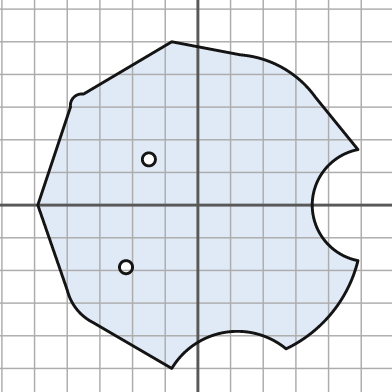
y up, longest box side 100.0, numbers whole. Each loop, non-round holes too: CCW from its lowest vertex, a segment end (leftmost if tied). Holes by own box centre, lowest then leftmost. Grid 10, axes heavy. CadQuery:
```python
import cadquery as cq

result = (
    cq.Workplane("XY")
    .moveTo(-8.0, -50.0)
    .threePointArc((8.0, -39.0), (27.0, -44.0))
    .threePointArc((41.0, -33.0), (49.0, -17.0))
    .threePointArc((35.0, 0.0), (49.0, 17.0))
    .lineTo(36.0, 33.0)
    .threePointArc((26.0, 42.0), (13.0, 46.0))
    .lineTo(-8.0, 50.0)
    .lineTo(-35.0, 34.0)
    .threePointArc((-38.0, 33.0), (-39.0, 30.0))
    .lineTo(-49.0, 0.0)
    .lineTo(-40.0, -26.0)
    .threePointArc((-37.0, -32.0), (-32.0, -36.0))
    .close()
    .moveTo(-22.0, -19.0)
    .circle(2.0)
    .moveTo(-15.0, 14.0)
    .circle(2.0)
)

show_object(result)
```